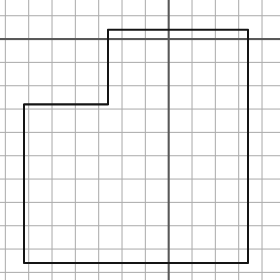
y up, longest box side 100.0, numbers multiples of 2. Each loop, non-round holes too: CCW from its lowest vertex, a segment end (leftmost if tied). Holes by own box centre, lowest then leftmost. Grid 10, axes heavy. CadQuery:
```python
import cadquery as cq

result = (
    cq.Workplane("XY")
    .moveTo(-62.0, -96.0)
    .lineTo(34.0, -96.0)
    .lineTo(34.0, 4.0)
    .lineTo(-26.0, 4.0)
    .lineTo(-26.0, -28.0)
    .lineTo(-62.0, -28.0)
    .close()
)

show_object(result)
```